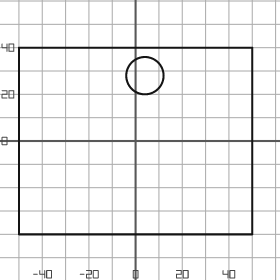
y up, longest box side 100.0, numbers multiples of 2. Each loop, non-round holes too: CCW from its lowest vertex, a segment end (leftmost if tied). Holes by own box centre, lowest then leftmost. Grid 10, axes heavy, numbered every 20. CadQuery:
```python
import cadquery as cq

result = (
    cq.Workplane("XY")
    .moveTo(-50.0, -40.0)
    .lineTo(50.0, -40.0)
    .lineTo(50.0, 40.0)
    .lineTo(-50.0, 40.0)
    .close()
    .moveTo(4.0, 28.0)
    .circle(8.0)
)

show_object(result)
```